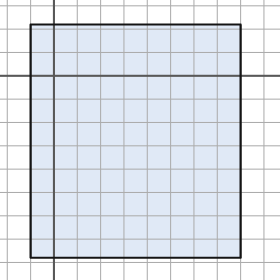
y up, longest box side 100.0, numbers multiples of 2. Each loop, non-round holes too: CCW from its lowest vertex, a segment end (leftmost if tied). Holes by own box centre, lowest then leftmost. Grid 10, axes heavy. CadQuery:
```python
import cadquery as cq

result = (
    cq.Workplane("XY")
    .moveTo(-10.0, -78.0)
    .lineTo(80.0, -78.0)
    .lineTo(80.0, 22.0)
    .lineTo(-10.0, 22.0)
    .close()
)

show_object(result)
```